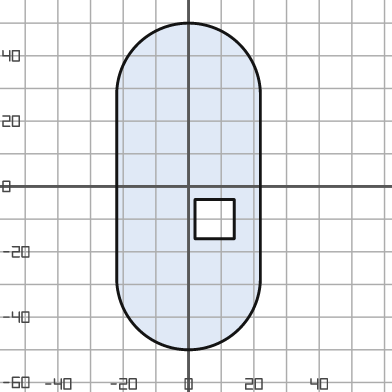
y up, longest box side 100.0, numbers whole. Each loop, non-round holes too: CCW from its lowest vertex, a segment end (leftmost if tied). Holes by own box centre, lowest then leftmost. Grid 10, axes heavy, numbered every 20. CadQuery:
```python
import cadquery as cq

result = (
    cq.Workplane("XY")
    .moveTo(-22.0, -28.0)
    .threePointArc((0.0, -50.0), (22.0, -28.0))
    .lineTo(22.0, 28.0)
    .threePointArc((0.0, 50.0), (-22.0, 28.0))
    .close()
    .moveTo(2.0, -16.0)
    .lineTo(14.0, -16.0)
    .lineTo(14.0, -4.0)
    .lineTo(2.0, -4.0)
    .close()
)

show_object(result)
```